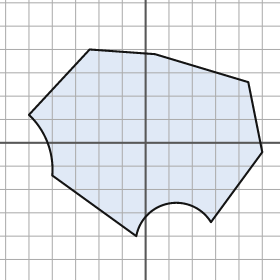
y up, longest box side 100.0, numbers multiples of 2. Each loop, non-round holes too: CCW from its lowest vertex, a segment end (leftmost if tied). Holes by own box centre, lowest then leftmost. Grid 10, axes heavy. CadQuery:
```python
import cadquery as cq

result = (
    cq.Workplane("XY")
    .moveTo(-4.0, -40.0)
    .threePointArc((10.0, -26.0), (28.0, -34.0))
    .lineTo(50.0, -4.0)
    .lineTo(44.0, 26.0)
    .lineTo(4.0, 38.0)
    .lineTo(-24.0, 40.0)
    .lineTo(-50.0, 12.0)
    .threePointArc((-42.0, 0.0), (-40.0, -14.0))
    .close()
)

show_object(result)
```